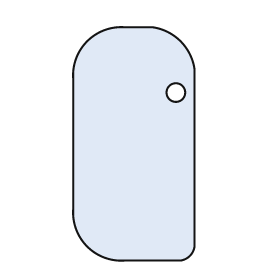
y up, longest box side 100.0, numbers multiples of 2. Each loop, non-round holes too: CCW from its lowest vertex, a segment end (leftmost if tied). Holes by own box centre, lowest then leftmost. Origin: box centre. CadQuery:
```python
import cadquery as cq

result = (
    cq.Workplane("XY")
    .moveTo(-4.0, -50.0)
    .lineTo(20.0, -50.0)
    .threePointArc((24.0, -48.0), (26.0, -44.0))
    .lineTo(26.0, 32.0)
    .threePointArc((20.0, 44.0), (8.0, 50.0))
    .lineTo(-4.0, 50.0)
    .threePointArc((-20.0, 44.0), (-26.0, 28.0))
    .lineTo(-26.0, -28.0)
    .threePointArc((-20.0, -44.0), (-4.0, -50.0))
    .close()
    .moveTo(18.0, 22.0)
    .circle(4.0)
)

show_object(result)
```